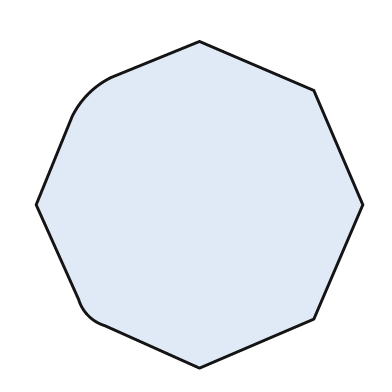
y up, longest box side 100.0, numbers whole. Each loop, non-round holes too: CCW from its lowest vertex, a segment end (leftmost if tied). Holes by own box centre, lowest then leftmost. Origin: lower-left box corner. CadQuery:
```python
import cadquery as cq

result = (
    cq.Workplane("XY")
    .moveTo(50.0, 0.0)
    .lineTo(85.0, 15.0)
    .lineTo(100.0, 50.0)
    .lineTo(85.0, 85.0)
    .lineTo(50.0, 100.0)
    .lineTo(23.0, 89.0)
    .threePointArc((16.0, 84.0), (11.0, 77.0))
    .lineTo(0.0, 50.0)
    .lineTo(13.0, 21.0)
    .threePointArc((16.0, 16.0), (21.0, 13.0))
    .close()
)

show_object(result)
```